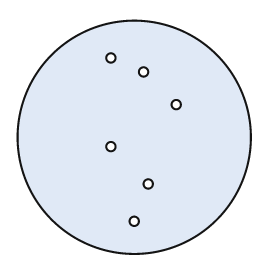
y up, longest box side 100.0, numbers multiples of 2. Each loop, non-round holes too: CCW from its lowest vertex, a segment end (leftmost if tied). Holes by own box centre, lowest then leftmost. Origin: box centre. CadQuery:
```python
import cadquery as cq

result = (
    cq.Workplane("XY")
    .moveTo(0.0, 0.0)
    .circle(50.0)
    .moveTo(0.0, -36.0)
    .circle(2.0)
    .moveTo(6.0, -20.0)
    .circle(2.0)
    .moveTo(-10.0, -4.0)
    .circle(2.0)
    .moveTo(18.0, 14.0)
    .circle(2.0)
    .moveTo(4.0, 28.0)
    .circle(2.0)
    .moveTo(-10.0, 34.0)
    .circle(2.0)
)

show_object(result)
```